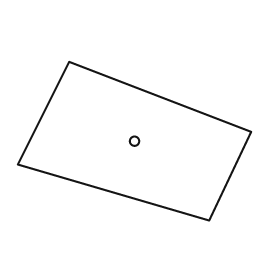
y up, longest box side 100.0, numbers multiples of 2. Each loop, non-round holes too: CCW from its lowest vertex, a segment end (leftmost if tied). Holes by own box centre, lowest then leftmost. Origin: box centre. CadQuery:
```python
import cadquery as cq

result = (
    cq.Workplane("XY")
    .moveTo(32.0, -34.0)
    .lineTo(50.0, 4.0)
    .lineTo(-28.0, 34.0)
    .lineTo(-50.0, -10.0)
    .close()
    .moveTo(0.0, 0.0)
    .circle(2.0)
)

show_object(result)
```